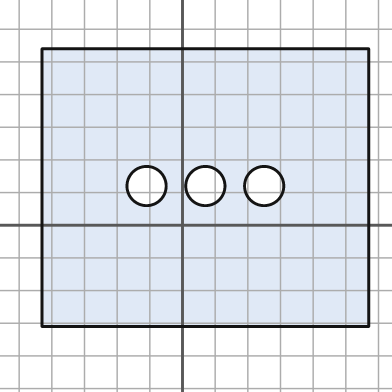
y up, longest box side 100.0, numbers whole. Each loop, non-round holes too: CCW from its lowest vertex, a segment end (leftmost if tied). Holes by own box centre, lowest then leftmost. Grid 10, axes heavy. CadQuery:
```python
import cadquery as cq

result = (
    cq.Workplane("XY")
    .moveTo(-43.0, -31.0)
    .lineTo(57.0, -31.0)
    .lineTo(57.0, 54.0)
    .lineTo(-43.0, 54.0)
    .close()
    .moveTo(-11.0, 12.0)
    .circle(6.0)
    .moveTo(7.0, 12.0)
    .circle(6.0)
    .moveTo(25.0, 12.0)
    .circle(6.0)
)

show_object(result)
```